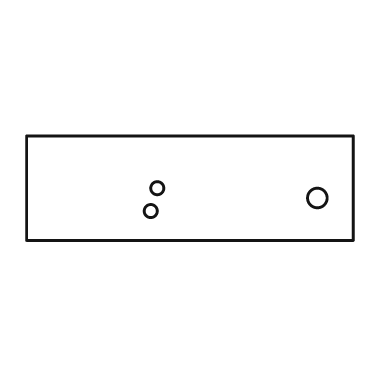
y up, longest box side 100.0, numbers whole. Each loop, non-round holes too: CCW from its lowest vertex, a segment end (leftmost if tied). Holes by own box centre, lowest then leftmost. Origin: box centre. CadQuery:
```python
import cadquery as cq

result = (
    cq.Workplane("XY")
    .moveTo(-50.0, -16.0)
    .lineTo(50.0, -16.0)
    .lineTo(50.0, 16.0)
    .lineTo(-50.0, 16.0)
    .close()
    .moveTo(-12.0, -7.0)
    .circle(2.0)
    .moveTo(39.0, -3.0)
    .circle(3.0)
    .moveTo(-10.0, 0.0)
    .circle(2.0)
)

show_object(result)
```